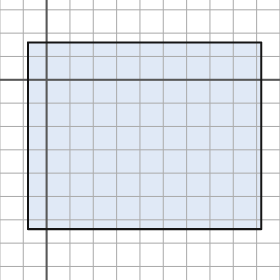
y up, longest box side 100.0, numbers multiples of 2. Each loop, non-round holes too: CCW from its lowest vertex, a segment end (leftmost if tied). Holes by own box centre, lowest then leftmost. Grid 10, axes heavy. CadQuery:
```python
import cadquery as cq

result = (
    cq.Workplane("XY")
    .moveTo(-8.0, -64.0)
    .lineTo(92.0, -64.0)
    .lineTo(92.0, 16.0)
    .lineTo(-8.0, 16.0)
    .close()
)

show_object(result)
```